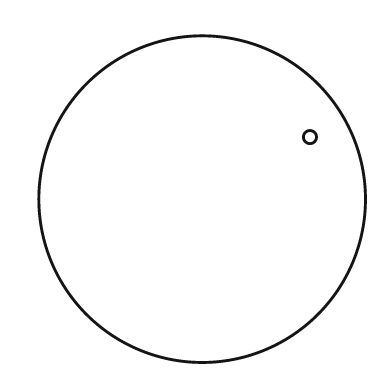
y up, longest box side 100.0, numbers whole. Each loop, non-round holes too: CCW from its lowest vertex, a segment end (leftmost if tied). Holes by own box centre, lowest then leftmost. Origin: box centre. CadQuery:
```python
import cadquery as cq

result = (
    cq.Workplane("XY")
    .moveTo(0.0, 0.0)
    .circle(50.0)
    .moveTo(33.0, 19.0)
    .circle(2.0)
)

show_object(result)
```